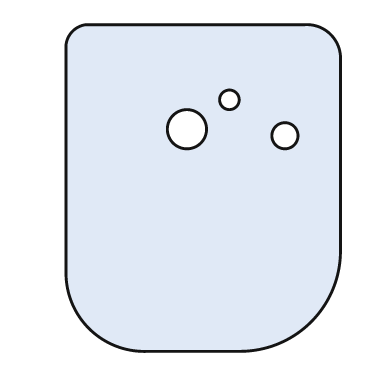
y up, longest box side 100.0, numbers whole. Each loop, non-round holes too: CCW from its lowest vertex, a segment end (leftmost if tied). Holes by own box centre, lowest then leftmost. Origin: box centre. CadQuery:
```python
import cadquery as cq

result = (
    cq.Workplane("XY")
    .moveTo(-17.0, -50.0)
    .lineTo(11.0, -50.0)
    .threePointArc((33.0, -41.0), (42.0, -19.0))
    .lineTo(42.0, 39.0)
    .threePointArc((39.0, 47.0), (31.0, 50.0))
    .lineTo(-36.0, 50.0)
    .threePointArc((-40.0, 48.0), (-42.0, 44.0))
    .lineTo(-42.0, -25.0)
    .threePointArc((-35.0, -43.0), (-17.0, -50.0))
    .close()
    .moveTo(25.0, 16.0)
    .circle(4.0)
    .moveTo(-5.0, 18.0)
    .circle(6.0)
    .moveTo(8.0, 27.0)
    .circle(3.0)
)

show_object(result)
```